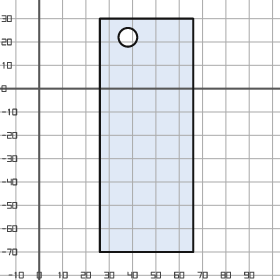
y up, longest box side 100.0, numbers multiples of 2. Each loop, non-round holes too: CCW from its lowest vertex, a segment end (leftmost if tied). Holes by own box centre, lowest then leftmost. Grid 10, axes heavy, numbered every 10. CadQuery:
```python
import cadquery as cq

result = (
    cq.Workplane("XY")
    .moveTo(26.0, -70.0)
    .lineTo(66.0, -70.0)
    .lineTo(66.0, 30.0)
    .lineTo(26.0, 30.0)
    .close()
    .moveTo(38.0, 22.0)
    .circle(4.0)
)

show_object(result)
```